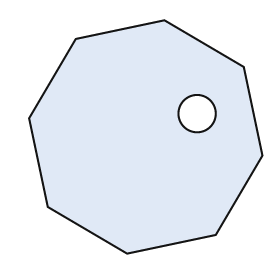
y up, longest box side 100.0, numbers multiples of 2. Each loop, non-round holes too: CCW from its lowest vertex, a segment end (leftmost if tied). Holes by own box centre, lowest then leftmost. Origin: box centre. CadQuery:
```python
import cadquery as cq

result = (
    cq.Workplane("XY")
    .moveTo(-8.0, -50.0)
    .lineTo(30.0, -42.0)
    .lineTo(50.0, -8.0)
    .lineTo(42.0, 30.0)
    .lineTo(8.0, 50.0)
    .lineTo(-30.0, 42.0)
    .lineTo(-50.0, 8.0)
    .lineTo(-42.0, -30.0)
    .close()
    .moveTo(22.0, 10.0)
    .circle(8.0)
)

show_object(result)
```